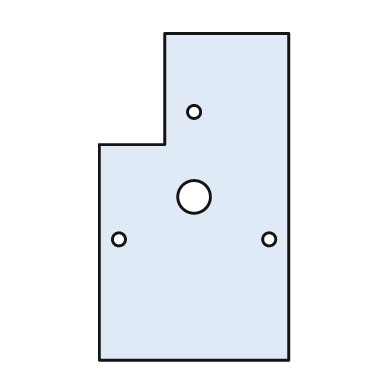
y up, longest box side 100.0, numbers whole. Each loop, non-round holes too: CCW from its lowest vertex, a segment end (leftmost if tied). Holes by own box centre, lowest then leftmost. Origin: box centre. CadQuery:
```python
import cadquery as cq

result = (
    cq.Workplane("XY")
    .moveTo(-29.0, -50.0)
    .lineTo(29.0, -50.0)
    .lineTo(29.0, 50.0)
    .lineTo(-9.0, 50.0)
    .lineTo(-9.0, 16.0)
    .lineTo(-29.0, 16.0)
    .close()
    .moveTo(-23.0, -13.0)
    .circle(2.0)
    .moveTo(23.0, -13.0)
    .circle(2.0)
    .moveTo(0.0, 0.0)
    .circle(5.0)
    .moveTo(0.0, 26.0)
    .circle(2.0)
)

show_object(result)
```